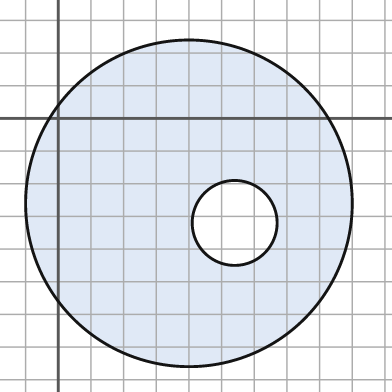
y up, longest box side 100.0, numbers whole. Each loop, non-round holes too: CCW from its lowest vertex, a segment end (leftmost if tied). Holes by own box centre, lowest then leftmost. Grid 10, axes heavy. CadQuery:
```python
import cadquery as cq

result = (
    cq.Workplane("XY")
    .moveTo(40.0, -26.0)
    .circle(50.0)
    .moveTo(54.0, -32.0)
    .circle(13.0)
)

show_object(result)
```